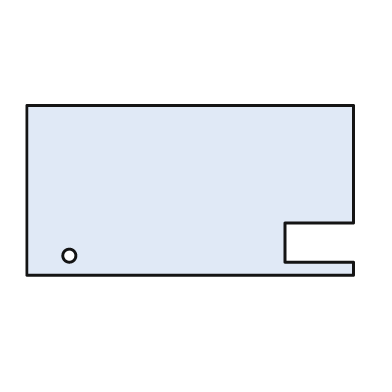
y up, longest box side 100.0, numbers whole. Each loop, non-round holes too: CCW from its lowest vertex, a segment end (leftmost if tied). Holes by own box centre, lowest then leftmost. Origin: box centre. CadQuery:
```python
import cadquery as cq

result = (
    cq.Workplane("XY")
    .moveTo(-50.0, -26.0)
    .lineTo(50.0, -26.0)
    .lineTo(50.0, -22.0)
    .lineTo(29.0, -22.0)
    .lineTo(29.0, -10.0)
    .lineTo(50.0, -10.0)
    .lineTo(50.0, 26.0)
    .lineTo(-50.0, 26.0)
    .close()
    .moveTo(-37.0, -20.0)
    .circle(2.0)
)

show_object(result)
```